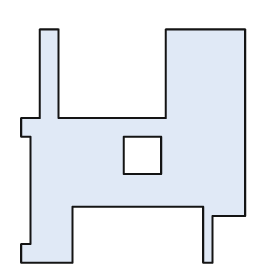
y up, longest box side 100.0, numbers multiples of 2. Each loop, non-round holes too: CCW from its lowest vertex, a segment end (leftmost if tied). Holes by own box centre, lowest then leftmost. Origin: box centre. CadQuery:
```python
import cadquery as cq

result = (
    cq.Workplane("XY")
    .moveTo(-48.0, -50.0)
    .lineTo(-26.0, -50.0)
    .lineTo(-26.0, -26.0)
    .lineTo(30.0, -26.0)
    .lineTo(30.0, -50.0)
    .lineTo(34.0, -50.0)
    .lineTo(34.0, -30.0)
    .lineTo(48.0, -30.0)
    .lineTo(48.0, 50.0)
    .lineTo(14.0, 50.0)
    .lineTo(14.0, 12.0)
    .lineTo(-32.0, 12.0)
    .lineTo(-32.0, 50.0)
    .lineTo(-40.0, 50.0)
    .lineTo(-40.0, 12.0)
    .lineTo(-48.0, 12.0)
    .lineTo(-48.0, 4.0)
    .lineTo(-44.0, 4.0)
    .lineTo(-44.0, -42.0)
    .lineTo(-48.0, -42.0)
    .close()
    .moveTo(-4.0, -12.0)
    .lineTo(12.0, -12.0)
    .lineTo(12.0, 4.0)
    .lineTo(-4.0, 4.0)
    .close()
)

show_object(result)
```